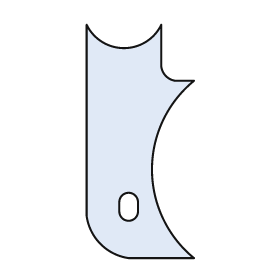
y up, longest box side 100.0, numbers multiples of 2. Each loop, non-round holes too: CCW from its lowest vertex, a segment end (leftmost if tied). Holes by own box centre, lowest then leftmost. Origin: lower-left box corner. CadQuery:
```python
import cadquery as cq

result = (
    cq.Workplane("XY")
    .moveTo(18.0, 0.0)
    .lineTo(46.0, 0.0)
    .threePointArc((28.0, 38.0), (46.0, 76.0))
    .lineTo(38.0, 76.0)
    .threePointArc((34.0, 78.0), (32.0, 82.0))
    .lineTo(32.0, 100.0)
    .threePointArc((16.0, 90.0), (0.0, 100.0))
    .lineTo(0.0, 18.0)
    .threePointArc((6.0, 6.0), (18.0, 0.0))
    .close()
    .moveTo(14.0, 20.0)
    .threePointArc((18.0, 16.0), (22.0, 20.0))
    .lineTo(22.0, 24.0)
    .threePointArc((18.0, 28.0), (14.0, 24.0))
    .close()
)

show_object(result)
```